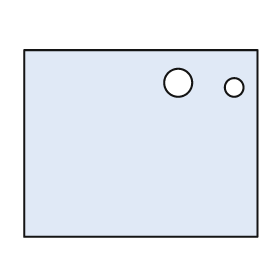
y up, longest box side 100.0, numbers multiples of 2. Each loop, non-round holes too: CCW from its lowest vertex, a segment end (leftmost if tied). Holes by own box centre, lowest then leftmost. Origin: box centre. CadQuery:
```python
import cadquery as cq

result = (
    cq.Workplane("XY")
    .moveTo(-50.0, -40.0)
    .lineTo(50.0, -40.0)
    .lineTo(50.0, 40.0)
    .lineTo(-50.0, 40.0)
    .close()
    .moveTo(40.0, 24.0)
    .circle(4.0)
    .moveTo(16.0, 26.0)
    .circle(6.0)
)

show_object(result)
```